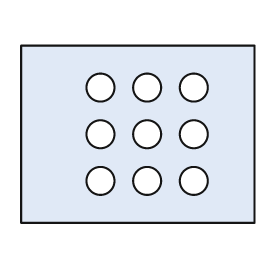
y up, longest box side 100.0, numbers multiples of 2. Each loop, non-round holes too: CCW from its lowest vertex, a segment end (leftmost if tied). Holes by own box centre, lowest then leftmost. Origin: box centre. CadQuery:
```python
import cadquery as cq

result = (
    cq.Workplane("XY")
    .moveTo(-50.0, -38.0)
    .lineTo(50.0, -38.0)
    .lineTo(50.0, 38.0)
    .lineTo(-50.0, 38.0)
    .close()
    .moveTo(-16.0, -20.0)
    .circle(6.0)
    .moveTo(4.0, -20.0)
    .circle(6.0)
    .moveTo(24.0, -20.0)
    .circle(6.0)
    .moveTo(-16.0, 0.0)
    .circle(6.0)
    .moveTo(4.0, 0.0)
    .circle(6.0)
    .moveTo(24.0, 0.0)
    .circle(6.0)
    .moveTo(-16.0, 20.0)
    .circle(6.0)
    .moveTo(4.0, 20.0)
    .circle(6.0)
    .moveTo(24.0, 20.0)
    .circle(6.0)
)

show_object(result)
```